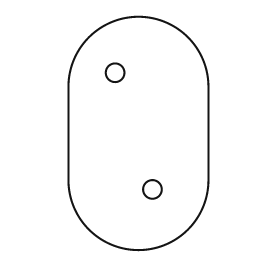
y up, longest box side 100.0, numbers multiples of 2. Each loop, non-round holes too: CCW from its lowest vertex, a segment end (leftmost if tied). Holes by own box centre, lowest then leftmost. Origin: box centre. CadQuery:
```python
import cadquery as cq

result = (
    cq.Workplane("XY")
    .moveTo(-30.0, -20.0)
    .threePointArc((0.0, -50.0), (30.0, -20.0))
    .lineTo(30.0, 20.0)
    .threePointArc((0.0, 50.0), (-30.0, 20.0))
    .close()
    .moveTo(6.0, -24.0)
    .circle(4.0)
    .moveTo(-10.0, 26.0)
    .circle(4.0)
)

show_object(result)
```